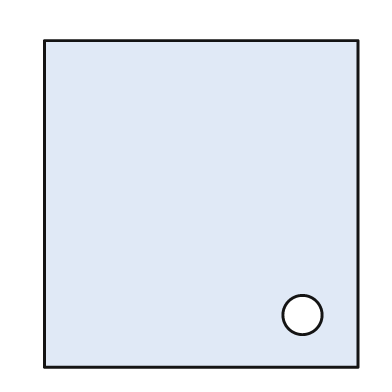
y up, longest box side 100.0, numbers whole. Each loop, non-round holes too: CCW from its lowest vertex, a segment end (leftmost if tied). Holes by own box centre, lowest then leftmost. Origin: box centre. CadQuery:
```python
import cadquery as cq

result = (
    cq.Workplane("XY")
    .moveTo(-48.0, -50.0)
    .lineTo(48.0, -50.0)
    .lineTo(48.0, 50.0)
    .lineTo(-48.0, 50.0)
    .close()
    .moveTo(31.0, -34.0)
    .circle(6.0)
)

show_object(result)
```